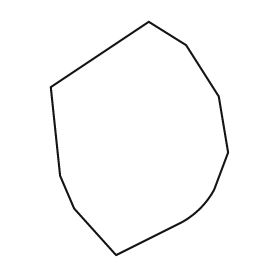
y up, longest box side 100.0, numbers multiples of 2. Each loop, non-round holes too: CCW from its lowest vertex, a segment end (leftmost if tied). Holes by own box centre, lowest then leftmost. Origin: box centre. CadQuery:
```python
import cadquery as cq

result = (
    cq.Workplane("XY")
    .moveTo(-10.0, -50.0)
    .lineTo(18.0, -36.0)
    .threePointArc((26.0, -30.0), (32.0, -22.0))
    .lineTo(38.0, -6.0)
    .lineTo(34.0, 18.0)
    .lineTo(20.0, 40.0)
    .lineTo(4.0, 50.0)
    .lineTo(-38.0, 22.0)
    .lineTo(-34.0, -16.0)
    .lineTo(-28.0, -30.0)
    .close()
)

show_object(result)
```